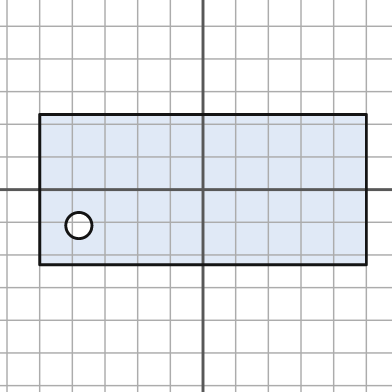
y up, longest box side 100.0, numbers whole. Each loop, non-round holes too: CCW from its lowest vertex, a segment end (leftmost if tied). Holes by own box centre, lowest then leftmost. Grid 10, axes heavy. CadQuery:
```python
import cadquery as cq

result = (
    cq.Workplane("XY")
    .moveTo(-50.0, -23.0)
    .lineTo(50.0, -23.0)
    .lineTo(50.0, 23.0)
    .lineTo(-50.0, 23.0)
    .close()
    .moveTo(-38.0, -11.0)
    .circle(4.0)
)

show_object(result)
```